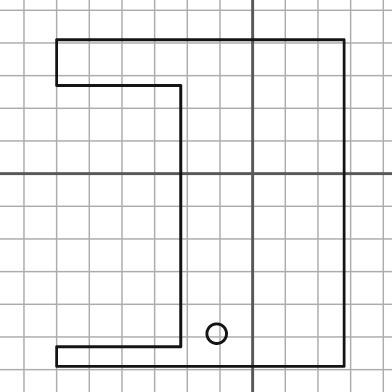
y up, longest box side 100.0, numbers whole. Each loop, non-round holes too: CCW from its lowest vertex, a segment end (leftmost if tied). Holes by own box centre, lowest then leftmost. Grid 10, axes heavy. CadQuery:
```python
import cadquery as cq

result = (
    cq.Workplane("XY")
    .moveTo(-60.0, -59.0)
    .lineTo(28.0, -59.0)
    .lineTo(28.0, 41.0)
    .lineTo(-60.0, 41.0)
    .lineTo(-60.0, 27.0)
    .lineTo(-22.0, 27.0)
    .lineTo(-22.0, -53.0)
    .lineTo(-60.0, -53.0)
    .close()
    .moveTo(-11.0, -49.0)
    .circle(3.0)
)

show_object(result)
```